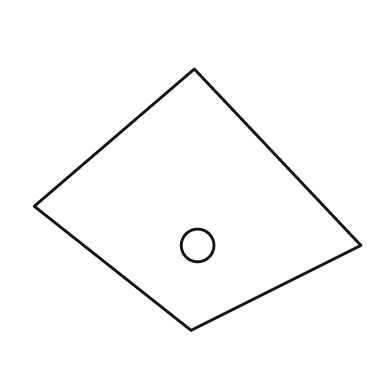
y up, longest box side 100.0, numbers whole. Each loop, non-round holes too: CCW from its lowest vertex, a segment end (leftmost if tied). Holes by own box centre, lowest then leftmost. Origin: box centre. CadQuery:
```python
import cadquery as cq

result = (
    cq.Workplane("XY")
    .moveTo(-2.0, -40.0)
    .lineTo(50.0, -14.0)
    .lineTo(-1.0, 40.0)
    .lineTo(-50.0, -2.0)
    .close()
    .moveTo(0.0, -14.0)
    .circle(5.0)
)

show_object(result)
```